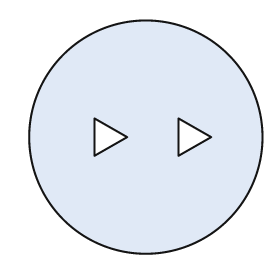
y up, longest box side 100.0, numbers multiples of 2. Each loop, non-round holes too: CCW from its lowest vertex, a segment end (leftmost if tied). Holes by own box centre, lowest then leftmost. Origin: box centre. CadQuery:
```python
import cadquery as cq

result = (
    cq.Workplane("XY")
    .moveTo(0.0, 0.0)
    .circle(50.0)
    .moveTo(-22.0, -8.0)
    .lineTo(-8.0, 0.0)
    .lineTo(-22.0, 8.0)
    .close()
    .moveTo(14.0, -8.0)
    .lineTo(28.0, 0.0)
    .lineTo(14.0, 8.0)
    .close()
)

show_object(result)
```